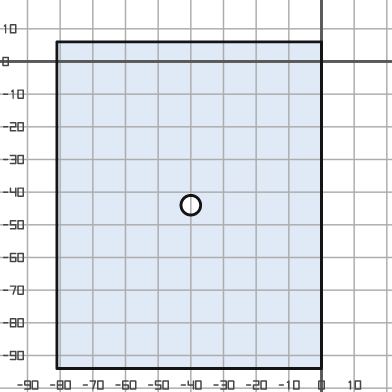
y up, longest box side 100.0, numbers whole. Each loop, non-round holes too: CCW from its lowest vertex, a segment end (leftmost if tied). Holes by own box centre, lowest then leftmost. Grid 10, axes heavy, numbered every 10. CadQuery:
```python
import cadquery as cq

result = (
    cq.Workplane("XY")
    .moveTo(-81.0, -94.0)
    .lineTo(0.0, -94.0)
    .lineTo(0.0, 6.0)
    .lineTo(-81.0, 6.0)
    .close()
    .moveTo(-40.0, -44.0)
    .circle(3.0)
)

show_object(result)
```